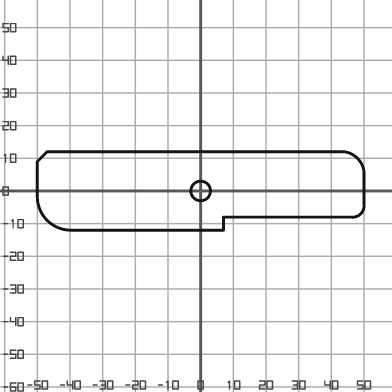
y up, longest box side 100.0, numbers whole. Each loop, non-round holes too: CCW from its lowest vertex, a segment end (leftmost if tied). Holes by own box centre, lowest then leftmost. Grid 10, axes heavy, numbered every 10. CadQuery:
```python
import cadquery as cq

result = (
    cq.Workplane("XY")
    .moveTo(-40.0, -12.0)
    .lineTo(7.0, -12.0)
    .lineTo(7.0, -8.0)
    .lineTo(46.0, -8.0)
    .threePointArc((49.0, -7.0), (50.0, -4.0))
    .lineTo(50.0, 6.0)
    .threePointArc((48.0, 10.0), (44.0, 12.0))
    .lineTo(-47.0, 12.0)
    .lineTo(-50.0, 9.0)
    .lineTo(-50.0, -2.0)
    .threePointArc((-47.0, -9.0), (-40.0, -12.0))
    .close()
    .moveTo(0.0, 0.0)
    .circle(3.0)
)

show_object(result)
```